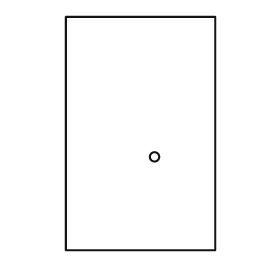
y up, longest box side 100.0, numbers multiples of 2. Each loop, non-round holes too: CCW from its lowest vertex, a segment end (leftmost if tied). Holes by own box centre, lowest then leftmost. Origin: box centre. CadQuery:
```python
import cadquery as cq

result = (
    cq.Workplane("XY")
    .moveTo(-32.0, -50.0)
    .lineTo(32.0, -50.0)
    .lineTo(32.0, 50.0)
    .lineTo(-32.0, 50.0)
    .close()
    .moveTo(6.0, -10.0)
    .circle(2.0)
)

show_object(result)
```